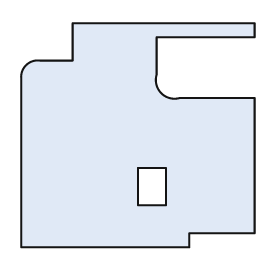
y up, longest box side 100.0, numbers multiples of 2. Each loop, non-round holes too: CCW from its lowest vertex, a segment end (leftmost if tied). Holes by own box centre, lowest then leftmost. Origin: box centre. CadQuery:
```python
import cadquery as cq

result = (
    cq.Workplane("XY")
    .moveTo(-50.0, -48.0)
    .lineTo(22.0, -48.0)
    .lineTo(22.0, -42.0)
    .lineTo(50.0, -42.0)
    .lineTo(50.0, 16.0)
    .lineTo(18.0, 16.0)
    .threePointArc((10.0, 18.0), (8.0, 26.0))
    .lineTo(8.0, 42.0)
    .lineTo(50.0, 42.0)
    .lineTo(50.0, 48.0)
    .lineTo(-28.0, 48.0)
    .lineTo(-28.0, 32.0)
    .lineTo(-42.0, 32.0)
    .threePointArc((-48.0, 30.0), (-50.0, 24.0))
    .close()
    .moveTo(0.0, -30.0)
    .lineTo(12.0, -30.0)
    .lineTo(12.0, -14.0)
    .lineTo(0.0, -14.0)
    .close()
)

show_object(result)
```